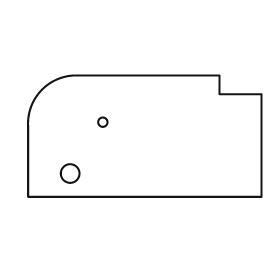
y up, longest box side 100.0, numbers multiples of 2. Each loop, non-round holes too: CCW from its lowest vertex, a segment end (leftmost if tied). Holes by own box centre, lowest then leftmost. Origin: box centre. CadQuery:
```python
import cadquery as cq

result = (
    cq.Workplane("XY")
    .moveTo(-50.0, -26.0)
    .lineTo(50.0, -26.0)
    .lineTo(50.0, 18.0)
    .lineTo(32.0, 18.0)
    .lineTo(32.0, 26.0)
    .lineTo(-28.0, 26.0)
    .threePointArc((-44.0, 20.0), (-50.0, 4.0))
    .close()
    .moveTo(-32.0, -16.0)
    .circle(4.0)
    .moveTo(-18.0, 6.0)
    .circle(2.0)
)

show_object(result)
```